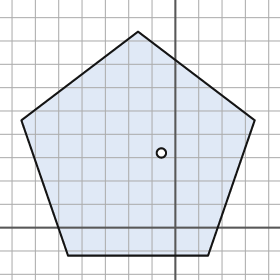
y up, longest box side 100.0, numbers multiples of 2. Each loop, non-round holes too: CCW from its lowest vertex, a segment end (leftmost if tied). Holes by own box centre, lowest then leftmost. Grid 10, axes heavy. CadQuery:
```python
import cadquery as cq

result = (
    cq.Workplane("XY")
    .moveTo(-46.0, -12.0)
    .lineTo(14.0, -12.0)
    .lineTo(34.0, 46.0)
    .lineTo(-16.0, 84.0)
    .lineTo(-66.0, 46.0)
    .close()
    .moveTo(-6.0, 32.0)
    .circle(2.0)
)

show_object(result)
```